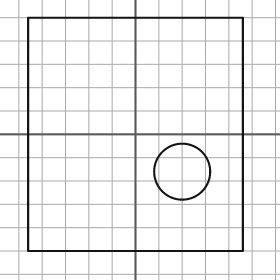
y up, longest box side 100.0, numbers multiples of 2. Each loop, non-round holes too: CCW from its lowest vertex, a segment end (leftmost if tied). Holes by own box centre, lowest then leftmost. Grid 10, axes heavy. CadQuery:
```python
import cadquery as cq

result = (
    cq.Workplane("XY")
    .moveTo(-46.0, -50.0)
    .lineTo(46.0, -50.0)
    .lineTo(46.0, 50.0)
    .lineTo(-46.0, 50.0)
    .close()
    .moveTo(20.0, -16.0)
    .circle(12.0)
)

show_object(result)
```